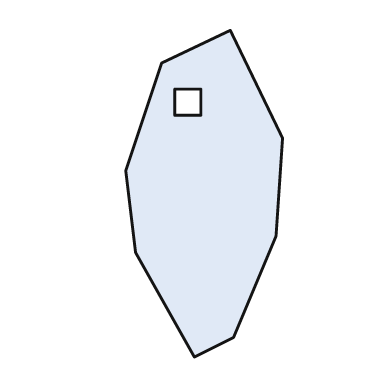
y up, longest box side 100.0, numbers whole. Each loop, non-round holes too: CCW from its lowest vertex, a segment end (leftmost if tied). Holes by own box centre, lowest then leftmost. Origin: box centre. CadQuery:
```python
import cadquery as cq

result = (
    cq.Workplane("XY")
    .moveTo(-3.0, -50.0)
    .lineTo(9.0, -44.0)
    .lineTo(22.0, -13.0)
    .lineTo(24.0, 17.0)
    .lineTo(8.0, 50.0)
    .lineTo(-13.0, 40.0)
    .lineTo(-24.0, 7.0)
    .lineTo(-21.0, -18.0)
    .close()
    .moveTo(-9.0, 24.0)
    .lineTo(-1.0, 24.0)
    .lineTo(-1.0, 32.0)
    .lineTo(-9.0, 32.0)
    .close()
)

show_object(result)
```